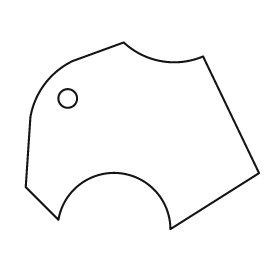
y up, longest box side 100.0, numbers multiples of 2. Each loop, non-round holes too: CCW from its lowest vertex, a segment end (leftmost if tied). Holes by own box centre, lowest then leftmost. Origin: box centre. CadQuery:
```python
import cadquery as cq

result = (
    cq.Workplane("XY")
    .moveTo(12.0, -40.0)
    .lineTo(50.0, -16.0)
    .lineTo(26.0, 34.0)
    .threePointArc((8.0, 32.0), (-8.0, 40.0))
    .lineTo(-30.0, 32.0)
    .threePointArc((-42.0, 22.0), (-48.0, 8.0))
    .lineTo(-50.0, -22.0)
    .lineTo(-36.0, -36.0)
    .threePointArc((-10.0, -16.0), (12.0, -40.0))
    .close()
    .moveTo(-32.0, 16.0)
    .circle(4.0)
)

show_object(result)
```